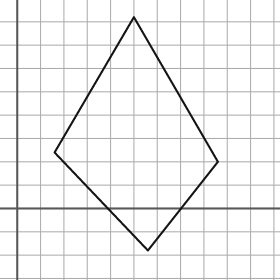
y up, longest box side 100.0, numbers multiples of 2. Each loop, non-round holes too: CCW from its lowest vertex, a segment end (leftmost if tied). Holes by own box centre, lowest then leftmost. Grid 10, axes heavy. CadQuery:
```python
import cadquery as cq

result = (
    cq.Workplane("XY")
    .moveTo(56.0, -18.0)
    .lineTo(86.0, 20.0)
    .lineTo(50.0, 82.0)
    .lineTo(16.0, 24.0)
    .close()
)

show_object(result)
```